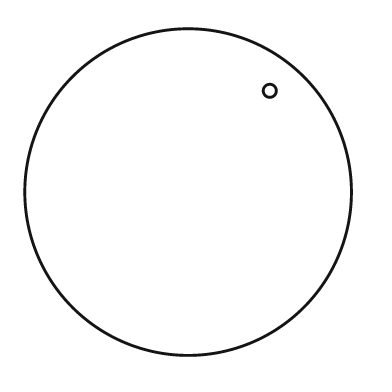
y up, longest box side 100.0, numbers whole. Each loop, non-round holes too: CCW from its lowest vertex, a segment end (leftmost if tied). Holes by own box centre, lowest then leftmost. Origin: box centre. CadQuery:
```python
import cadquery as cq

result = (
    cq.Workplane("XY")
    .moveTo(0.0, 0.0)
    .circle(50.0)
    .moveTo(25.0, 31.0)
    .circle(2.0)
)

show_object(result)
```